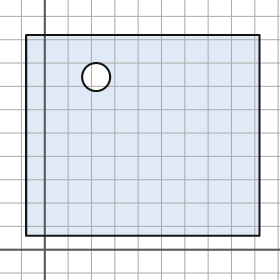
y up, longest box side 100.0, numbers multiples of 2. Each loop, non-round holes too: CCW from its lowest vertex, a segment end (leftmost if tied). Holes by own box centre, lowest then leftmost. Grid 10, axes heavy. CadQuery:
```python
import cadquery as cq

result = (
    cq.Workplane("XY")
    .moveTo(-8.0, 6.0)
    .lineTo(92.0, 6.0)
    .lineTo(92.0, 92.0)
    .lineTo(-8.0, 92.0)
    .close()
    .moveTo(22.0, 74.0)
    .circle(6.0)
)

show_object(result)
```